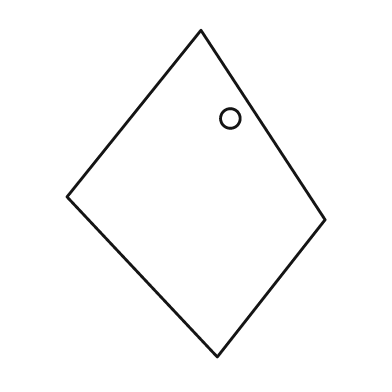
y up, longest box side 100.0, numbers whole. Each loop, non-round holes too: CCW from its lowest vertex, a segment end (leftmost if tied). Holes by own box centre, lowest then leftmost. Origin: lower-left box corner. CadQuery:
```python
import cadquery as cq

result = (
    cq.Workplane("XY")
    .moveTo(46.0, 0.0)
    .lineTo(79.0, 42.0)
    .lineTo(41.0, 100.0)
    .lineTo(0.0, 49.0)
    .close()
    .moveTo(50.0, 73.0)
    .circle(3.0)
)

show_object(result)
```